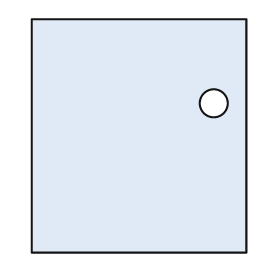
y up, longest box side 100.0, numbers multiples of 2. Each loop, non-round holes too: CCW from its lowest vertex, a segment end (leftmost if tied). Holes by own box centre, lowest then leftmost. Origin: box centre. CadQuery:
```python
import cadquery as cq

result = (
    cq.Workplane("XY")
    .moveTo(-46.0, -50.0)
    .lineTo(46.0, -50.0)
    .lineTo(46.0, 50.0)
    .lineTo(-46.0, 50.0)
    .close()
    .moveTo(32.0, 14.0)
    .circle(6.0)
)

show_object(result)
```